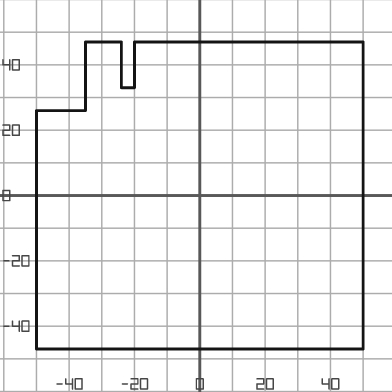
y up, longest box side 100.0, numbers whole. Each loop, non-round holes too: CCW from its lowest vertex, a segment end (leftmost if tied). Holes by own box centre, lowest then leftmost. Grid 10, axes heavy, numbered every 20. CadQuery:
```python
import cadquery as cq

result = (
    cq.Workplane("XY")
    .moveTo(-50.0, -47.0)
    .lineTo(50.0, -47.0)
    .lineTo(50.0, 47.0)
    .lineTo(-20.0, 47.0)
    .lineTo(-20.0, 33.0)
    .lineTo(-24.0, 33.0)
    .lineTo(-24.0, 47.0)
    .lineTo(-35.0, 47.0)
    .lineTo(-35.0, 26.0)
    .lineTo(-50.0, 26.0)
    .close()
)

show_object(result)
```